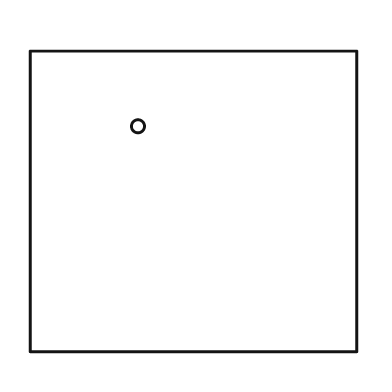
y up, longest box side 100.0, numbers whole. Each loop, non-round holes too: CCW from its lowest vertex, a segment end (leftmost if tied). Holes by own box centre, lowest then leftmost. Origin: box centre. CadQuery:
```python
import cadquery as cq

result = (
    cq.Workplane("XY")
    .moveTo(-50.0, -46.0)
    .lineTo(50.0, -46.0)
    .lineTo(50.0, 46.0)
    .lineTo(-50.0, 46.0)
    .close()
    .moveTo(-17.0, 23.0)
    .circle(2.0)
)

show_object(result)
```